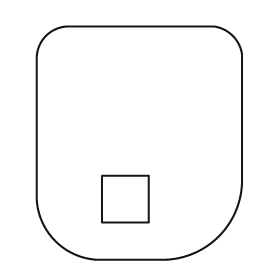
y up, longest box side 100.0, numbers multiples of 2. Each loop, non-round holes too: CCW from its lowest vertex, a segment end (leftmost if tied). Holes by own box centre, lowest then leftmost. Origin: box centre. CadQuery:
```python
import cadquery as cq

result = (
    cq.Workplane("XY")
    .moveTo(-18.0, -50.0)
    .lineTo(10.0, -50.0)
    .threePointArc((34.0, -40.0), (44.0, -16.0))
    .lineTo(44.0, 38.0)
    .threePointArc((40.0, 46.0), (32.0, 50.0))
    .lineTo(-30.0, 50.0)
    .threePointArc((-40.0, 46.0), (-44.0, 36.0))
    .lineTo(-44.0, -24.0)
    .threePointArc((-36.0, -42.0), (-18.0, -50.0))
    .close()
    .moveTo(-16.0, -34.0)
    .lineTo(4.0, -34.0)
    .lineTo(4.0, -14.0)
    .lineTo(-16.0, -14.0)
    .close()
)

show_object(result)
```